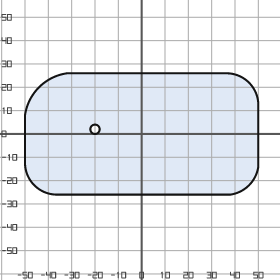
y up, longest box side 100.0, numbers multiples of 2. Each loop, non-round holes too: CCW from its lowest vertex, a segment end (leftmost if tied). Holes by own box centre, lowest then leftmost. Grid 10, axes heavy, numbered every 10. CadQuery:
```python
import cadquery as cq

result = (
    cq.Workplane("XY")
    .moveTo(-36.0, -26.0)
    .lineTo(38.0, -26.0)
    .threePointArc((46.0, -22.0), (50.0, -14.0))
    .lineTo(50.0, 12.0)
    .threePointArc((46.0, 22.0), (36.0, 26.0))
    .lineTo(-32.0, 26.0)
    .threePointArc((-44.0, 20.0), (-50.0, 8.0))
    .lineTo(-50.0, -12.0)
    .threePointArc((-46.0, -22.0), (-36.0, -26.0))
    .close()
    .moveTo(-20.0, 2.0)
    .circle(2.0)
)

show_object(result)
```